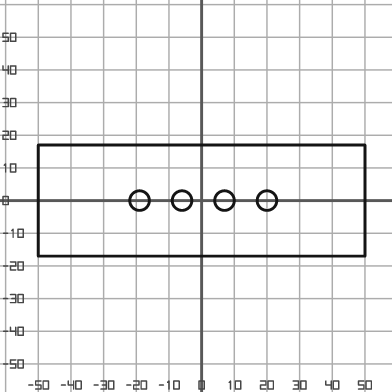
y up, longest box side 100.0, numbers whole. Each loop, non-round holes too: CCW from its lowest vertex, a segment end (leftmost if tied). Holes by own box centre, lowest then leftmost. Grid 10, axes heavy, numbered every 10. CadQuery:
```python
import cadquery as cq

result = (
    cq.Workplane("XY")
    .moveTo(-50.0, -17.0)
    .lineTo(50.0, -17.0)
    .lineTo(50.0, 17.0)
    .lineTo(-50.0, 17.0)
    .close()
    .moveTo(-19.0, 0.0)
    .circle(3.0)
    .moveTo(-6.0, 0.0)
    .circle(3.0)
    .moveTo(7.0, 0.0)
    .circle(3.0)
    .moveTo(20.0, 0.0)
    .circle(3.0)
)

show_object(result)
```